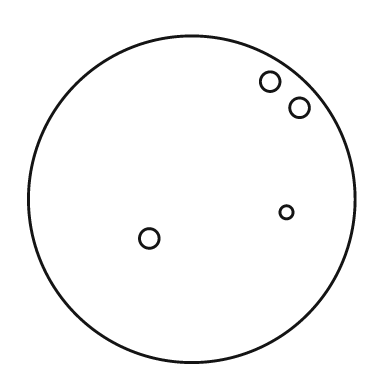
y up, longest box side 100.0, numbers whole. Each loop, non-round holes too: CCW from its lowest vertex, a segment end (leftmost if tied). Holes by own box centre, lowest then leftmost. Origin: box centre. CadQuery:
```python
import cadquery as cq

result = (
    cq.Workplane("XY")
    .moveTo(0.0, 0.0)
    .circle(50.0)
    .moveTo(-13.0, -12.0)
    .circle(3.0)
    .moveTo(29.0, -4.0)
    .circle(2.0)
    .moveTo(33.0, 28.0)
    .circle(3.0)
    .moveTo(24.0, 36.0)
    .circle(3.0)
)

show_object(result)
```